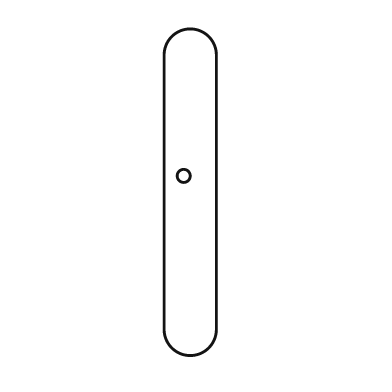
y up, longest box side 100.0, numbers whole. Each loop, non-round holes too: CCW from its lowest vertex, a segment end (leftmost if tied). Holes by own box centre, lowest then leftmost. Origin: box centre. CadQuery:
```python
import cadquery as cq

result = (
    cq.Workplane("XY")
    .moveTo(-8.0, -42.0)
    .threePointArc((0.0, -50.0), (8.0, -42.0))
    .lineTo(8.0, 42.0)
    .threePointArc((0.0, 50.0), (-8.0, 42.0))
    .close()
    .moveTo(-2.0, 5.0)
    .circle(2.0)
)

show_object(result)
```